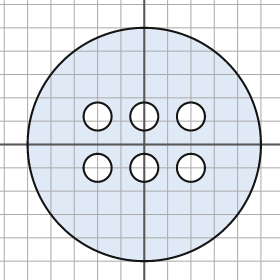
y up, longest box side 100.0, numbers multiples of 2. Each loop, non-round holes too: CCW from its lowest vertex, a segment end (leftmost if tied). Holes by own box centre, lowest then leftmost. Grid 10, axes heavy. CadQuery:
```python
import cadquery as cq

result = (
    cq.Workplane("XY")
    .moveTo(0.0, 0.0)
    .circle(50.0)
    .moveTo(-20.0, -10.0)
    .circle(6.0)
    .moveTo(0.0, -10.0)
    .circle(6.0)
    .moveTo(20.0, -10.0)
    .circle(6.0)
    .moveTo(-20.0, 12.0)
    .circle(6.0)
    .moveTo(0.0, 12.0)
    .circle(6.0)
    .moveTo(20.0, 12.0)
    .circle(6.0)
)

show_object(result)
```